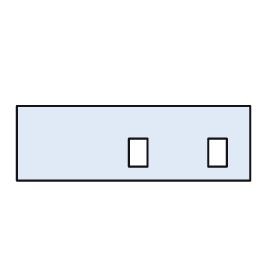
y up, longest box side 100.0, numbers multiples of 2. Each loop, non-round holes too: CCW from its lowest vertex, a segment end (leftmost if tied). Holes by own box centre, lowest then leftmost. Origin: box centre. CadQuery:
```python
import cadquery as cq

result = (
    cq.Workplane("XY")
    .moveTo(-50.0, -16.0)
    .lineTo(50.0, -16.0)
    .lineTo(50.0, 16.0)
    .lineTo(-50.0, 16.0)
    .close()
    .moveTo(-2.0, -10.0)
    .lineTo(6.0, -10.0)
    .lineTo(6.0, 2.0)
    .lineTo(-2.0, 2.0)
    .close()
    .moveTo(32.0, -10.0)
    .lineTo(40.0, -10.0)
    .lineTo(40.0, 2.0)
    .lineTo(32.0, 2.0)
    .close()
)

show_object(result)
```